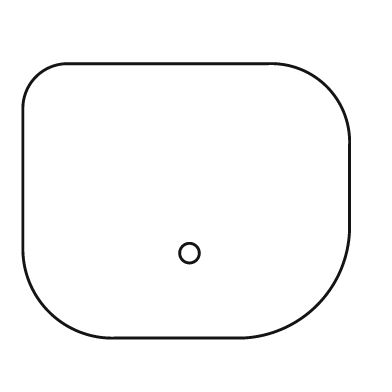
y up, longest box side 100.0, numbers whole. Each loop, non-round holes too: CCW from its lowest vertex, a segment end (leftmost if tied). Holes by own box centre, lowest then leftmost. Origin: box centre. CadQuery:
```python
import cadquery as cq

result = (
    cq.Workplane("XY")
    .moveTo(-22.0, -42.0)
    .lineTo(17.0, -42.0)
    .threePointArc((40.0, -32.0), (50.0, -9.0))
    .lineTo(50.0, 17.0)
    .threePointArc((43.0, 35.0), (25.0, 42.0))
    .lineTo(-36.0, 42.0)
    .threePointArc((-46.0, 38.0), (-50.0, 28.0))
    .lineTo(-50.0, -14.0)
    .threePointArc((-42.0, -34.0), (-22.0, -42.0))
    .close()
    .moveTo(1.0, -16.0)
    .circle(3.0)
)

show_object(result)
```